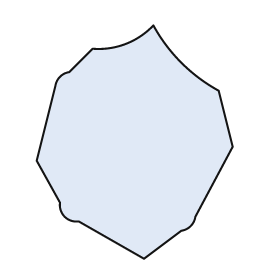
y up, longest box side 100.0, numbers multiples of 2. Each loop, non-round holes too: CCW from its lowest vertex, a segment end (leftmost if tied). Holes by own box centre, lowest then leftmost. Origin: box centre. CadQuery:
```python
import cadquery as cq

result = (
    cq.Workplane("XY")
    .moveTo(4.0, -50.0)
    .lineTo(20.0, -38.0)
    .threePointArc((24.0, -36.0), (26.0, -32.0))
    .lineTo(42.0, -2.0)
    .lineTo(36.0, 22.0)
    .threePointArc((20.0, 34.0), (8.0, 50.0))
    .threePointArc((-4.0, 42.0), (-18.0, 40.0))
    .lineTo(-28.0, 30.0)
    .threePointArc((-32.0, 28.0), (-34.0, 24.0))
    .lineTo(-42.0, -8.0)
    .lineTo(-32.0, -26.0)
    .threePointArc((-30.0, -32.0), (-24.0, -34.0))
    .close()
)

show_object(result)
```